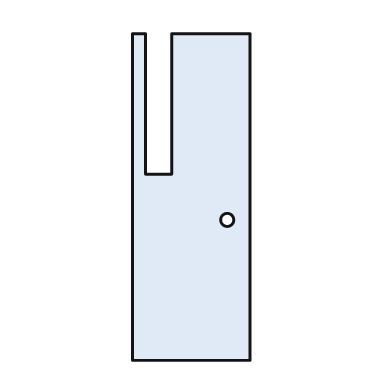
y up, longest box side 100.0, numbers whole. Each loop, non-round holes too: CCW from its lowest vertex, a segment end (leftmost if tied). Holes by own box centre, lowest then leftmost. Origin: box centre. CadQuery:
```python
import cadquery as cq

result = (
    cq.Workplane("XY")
    .moveTo(-18.0, -50.0)
    .lineTo(18.0, -50.0)
    .lineTo(18.0, 50.0)
    .lineTo(-6.0, 50.0)
    .lineTo(-6.0, 7.0)
    .lineTo(-14.0, 7.0)
    .lineTo(-14.0, 50.0)
    .lineTo(-18.0, 50.0)
    .close()
    .moveTo(11.0, -7.0)
    .circle(2.0)
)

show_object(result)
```